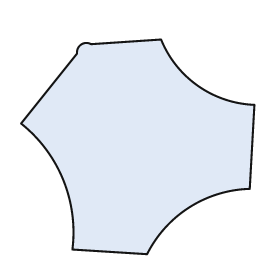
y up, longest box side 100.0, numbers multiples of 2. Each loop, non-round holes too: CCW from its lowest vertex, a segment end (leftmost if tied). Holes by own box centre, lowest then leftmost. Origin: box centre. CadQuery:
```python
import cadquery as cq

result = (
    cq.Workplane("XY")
    .moveTo(4.0, -46.0)
    .threePointArc((22.0, -26.0), (48.0, -18.0))
    .lineTo(50.0, 18.0)
    .threePointArc((26.0, 26.0), (10.0, 46.0))
    .lineTo(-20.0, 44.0)
    .threePointArc((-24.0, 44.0), (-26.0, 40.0))
    .lineTo(-50.0, 10.0)
    .threePointArc((-32.0, -14.0), (-28.0, -44.0))
    .close()
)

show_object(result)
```